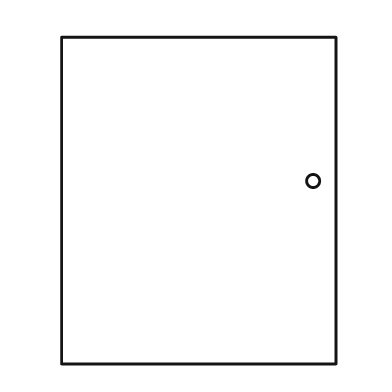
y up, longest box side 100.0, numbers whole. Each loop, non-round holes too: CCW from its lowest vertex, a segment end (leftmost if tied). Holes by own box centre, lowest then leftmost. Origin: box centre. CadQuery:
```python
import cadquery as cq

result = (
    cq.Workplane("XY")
    .moveTo(-42.0, -50.0)
    .lineTo(42.0, -50.0)
    .lineTo(42.0, 50.0)
    .lineTo(-42.0, 50.0)
    .close()
    .moveTo(35.0, 6.0)
    .circle(2.0)
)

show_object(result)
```